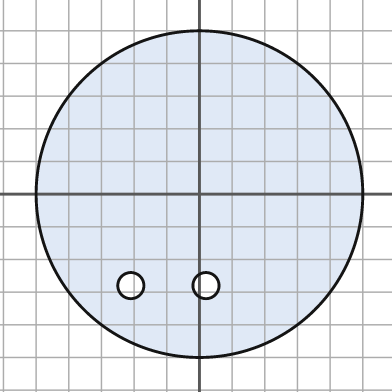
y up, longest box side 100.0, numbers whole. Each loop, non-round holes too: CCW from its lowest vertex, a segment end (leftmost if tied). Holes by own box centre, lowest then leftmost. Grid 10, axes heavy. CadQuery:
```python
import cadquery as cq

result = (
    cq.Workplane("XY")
    .moveTo(0.0, 0.0)
    .circle(50.0)
    .moveTo(-21.0, -28.0)
    .circle(4.0)
    .moveTo(2.0, -28.0)
    .circle(4.0)
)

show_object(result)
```